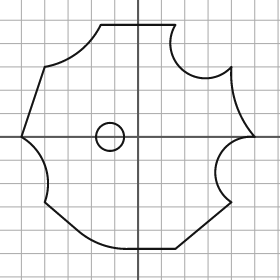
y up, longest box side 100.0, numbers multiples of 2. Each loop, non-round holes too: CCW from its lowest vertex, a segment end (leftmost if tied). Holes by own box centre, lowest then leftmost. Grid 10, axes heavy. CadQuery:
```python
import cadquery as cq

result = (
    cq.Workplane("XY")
    .moveTo(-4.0, -48.0)
    .lineTo(16.0, -48.0)
    .lineTo(40.0, -28.0)
    .threePointArc((34.0, -10.0), (50.0, 0.0))
    .threePointArc((42.0, 14.0), (40.0, 30.0))
    .threePointArc((20.0, 28.0), (16.0, 48.0))
    .lineTo(-16.0, 48.0)
    .threePointArc((-26.0, 36.0), (-40.0, 30.0))
    .lineTo(-50.0, 0.0)
    .threePointArc((-40.0, -12.0), (-40.0, -28.0))
    .lineTo(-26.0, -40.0)
    .threePointArc((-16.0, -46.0), (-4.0, -48.0))
    .close()
    .moveTo(-12.0, 0.0)
    .circle(6.0)
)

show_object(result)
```